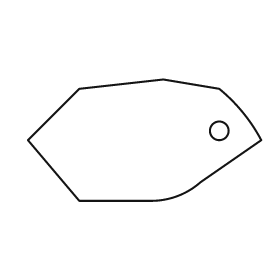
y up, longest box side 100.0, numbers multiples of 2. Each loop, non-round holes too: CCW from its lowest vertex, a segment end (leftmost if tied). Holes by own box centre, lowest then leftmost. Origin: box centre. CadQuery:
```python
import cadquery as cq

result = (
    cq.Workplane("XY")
    .moveTo(-28.0, -26.0)
    .lineTo(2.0, -26.0)
    .threePointArc((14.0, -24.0), (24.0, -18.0))
    .lineTo(50.0, 0.0)
    .threePointArc((42.0, 12.0), (32.0, 22.0))
    .lineTo(8.0, 26.0)
    .lineTo(-28.0, 22.0)
    .lineTo(-50.0, 0.0)
    .close()
    .moveTo(32.0, 4.0)
    .circle(4.0)
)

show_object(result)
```